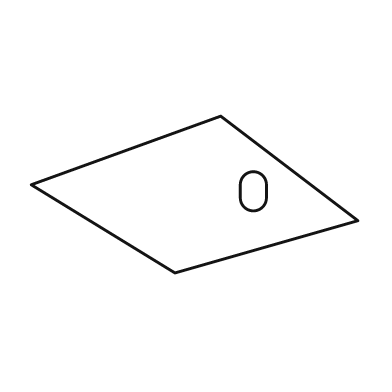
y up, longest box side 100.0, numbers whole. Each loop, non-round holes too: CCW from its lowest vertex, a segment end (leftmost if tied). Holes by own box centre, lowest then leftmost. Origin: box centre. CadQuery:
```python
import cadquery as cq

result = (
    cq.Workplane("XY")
    .moveTo(-6.0, -24.0)
    .lineTo(50.0, -8.0)
    .lineTo(8.0, 24.0)
    .lineTo(-50.0, 3.0)
    .close()
    .moveTo(14.0, -1.0)
    .threePointArc((18.0, -5.0), (22.0, -1.0))
    .lineTo(22.0, 3.0)
    .threePointArc((18.0, 7.0), (14.0, 3.0))
    .close()
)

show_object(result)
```